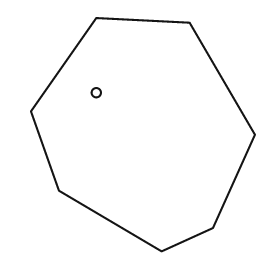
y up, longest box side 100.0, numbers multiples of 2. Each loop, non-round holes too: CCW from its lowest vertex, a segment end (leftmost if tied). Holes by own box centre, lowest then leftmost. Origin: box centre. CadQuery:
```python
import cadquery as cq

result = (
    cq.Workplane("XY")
    .moveTo(8.0, -50.0)
    .lineTo(30.0, -40.0)
    .lineTo(48.0, 0.0)
    .lineTo(20.0, 48.0)
    .lineTo(-20.0, 50.0)
    .lineTo(-48.0, 10.0)
    .lineTo(-36.0, -24.0)
    .close()
    .moveTo(-20.0, 18.0)
    .circle(2.0)
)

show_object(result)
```